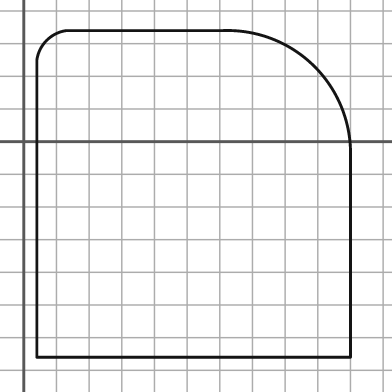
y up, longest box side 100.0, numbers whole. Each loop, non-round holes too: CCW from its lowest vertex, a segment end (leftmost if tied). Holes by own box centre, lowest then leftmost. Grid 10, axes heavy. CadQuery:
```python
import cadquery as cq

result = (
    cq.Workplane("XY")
    .moveTo(4.0, -66.0)
    .lineTo(100.0, -66.0)
    .lineTo(100.0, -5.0)
    .threePointArc((89.0, 23.0), (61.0, 34.0))
    .lineTo(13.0, 34.0)
    .threePointArc((7.0, 31.0), (4.0, 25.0))
    .close()
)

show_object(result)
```